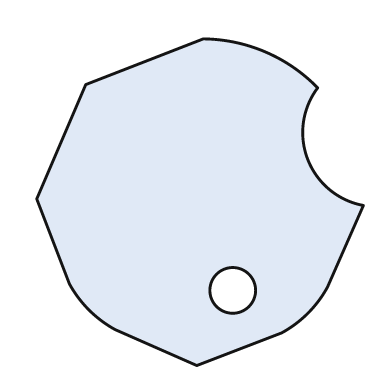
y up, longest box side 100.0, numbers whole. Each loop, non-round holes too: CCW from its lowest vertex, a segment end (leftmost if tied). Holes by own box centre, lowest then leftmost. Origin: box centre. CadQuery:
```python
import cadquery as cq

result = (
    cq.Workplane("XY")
    .moveTo(-1.0, -50.0)
    .lineTo(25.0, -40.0)
    .threePointArc((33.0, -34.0), (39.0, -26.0))
    .lineTo(50.0, -1.0)
    .threePointArc((33.0, 13.0), (36.0, 35.0))
    .threePointArc((20.0, 46.0), (1.0, 50.0))
    .lineTo(-35.0, 36.0)
    .lineTo(-50.0, 1.0)
    .lineTo(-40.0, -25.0)
    .threePointArc((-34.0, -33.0), (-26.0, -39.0))
    .close()
    .moveTo(10.0, -27.0)
    .circle(7.0)
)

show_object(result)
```